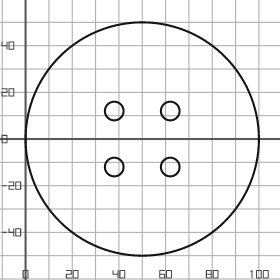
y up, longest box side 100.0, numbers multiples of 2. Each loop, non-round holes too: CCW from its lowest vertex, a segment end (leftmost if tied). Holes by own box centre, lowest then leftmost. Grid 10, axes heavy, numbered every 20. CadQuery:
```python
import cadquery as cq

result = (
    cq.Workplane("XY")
    .moveTo(50.0, 0.0)
    .circle(50.0)
    .moveTo(38.0, -12.0)
    .circle(4.0)
    .moveTo(62.0, -12.0)
    .circle(4.0)
    .moveTo(38.0, 12.0)
    .circle(4.0)
    .moveTo(62.0, 12.0)
    .circle(4.0)
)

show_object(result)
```